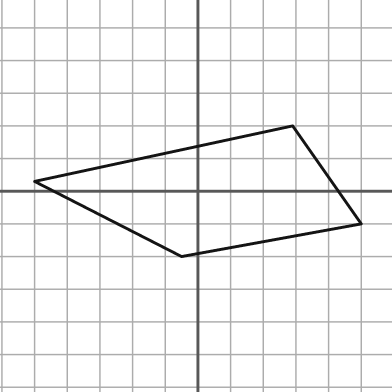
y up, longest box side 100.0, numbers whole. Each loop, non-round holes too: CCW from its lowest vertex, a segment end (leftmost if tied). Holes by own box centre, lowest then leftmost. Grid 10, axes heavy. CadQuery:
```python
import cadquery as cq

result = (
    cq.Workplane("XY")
    .moveTo(-5.0, -20.0)
    .lineTo(50.0, -10.0)
    .lineTo(29.0, 20.0)
    .lineTo(-50.0, 3.0)
    .close()
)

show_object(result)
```